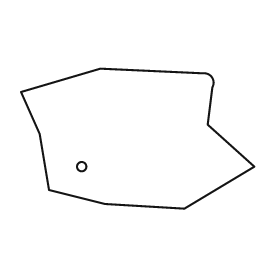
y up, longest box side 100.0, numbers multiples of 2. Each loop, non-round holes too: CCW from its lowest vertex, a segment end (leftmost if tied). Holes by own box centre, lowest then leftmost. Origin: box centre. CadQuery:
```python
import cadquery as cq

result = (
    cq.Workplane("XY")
    .moveTo(20.0, -30.0)
    .lineTo(50.0, -12.0)
    .lineTo(30.0, 6.0)
    .lineTo(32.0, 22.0)
    .threePointArc((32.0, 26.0), (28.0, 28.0))
    .lineTo(-16.0, 30.0)
    .lineTo(-50.0, 20.0)
    .lineTo(-42.0, 2.0)
    .lineTo(-38.0, -22.0)
    .lineTo(-14.0, -28.0)
    .close()
    .moveTo(-24.0, -12.0)
    .circle(2.0)
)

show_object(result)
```